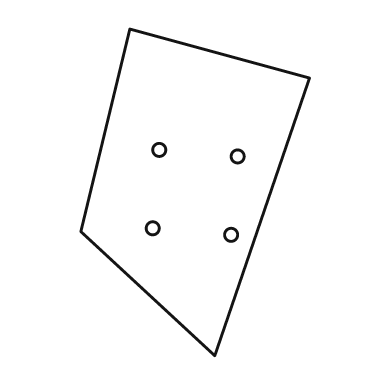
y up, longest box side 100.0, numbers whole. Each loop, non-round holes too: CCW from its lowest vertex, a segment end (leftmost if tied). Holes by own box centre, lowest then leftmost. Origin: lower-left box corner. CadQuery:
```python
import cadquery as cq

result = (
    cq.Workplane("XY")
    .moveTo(41.0, 0.0)
    .lineTo(70.0, 85.0)
    .lineTo(15.0, 100.0)
    .lineTo(0.0, 38.0)
    .close()
    .moveTo(46.0, 37.0)
    .circle(2.0)
    .moveTo(22.0, 39.0)
    .circle(2.0)
    .moveTo(48.0, 61.0)
    .circle(2.0)
    .moveTo(24.0, 63.0)
    .circle(2.0)
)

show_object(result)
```